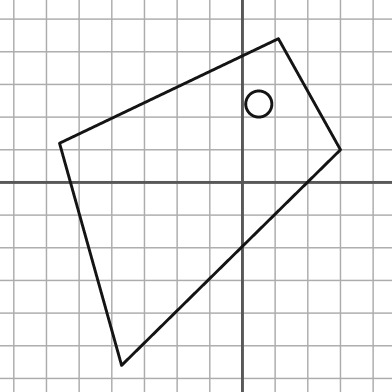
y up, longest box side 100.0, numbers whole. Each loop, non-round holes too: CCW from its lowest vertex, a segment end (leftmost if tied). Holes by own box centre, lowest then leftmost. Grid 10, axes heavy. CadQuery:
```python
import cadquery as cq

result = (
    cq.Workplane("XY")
    .moveTo(-37.0, -56.0)
    .lineTo(30.0, 10.0)
    .lineTo(11.0, 44.0)
    .lineTo(-56.0, 12.0)
    .close()
    .moveTo(5.0, 24.0)
    .circle(4.0)
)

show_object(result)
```